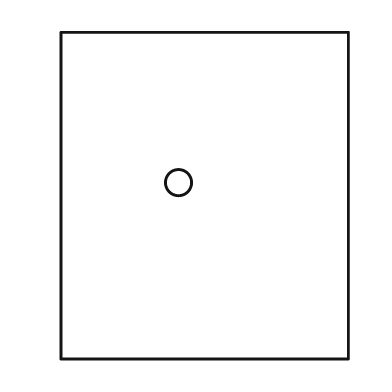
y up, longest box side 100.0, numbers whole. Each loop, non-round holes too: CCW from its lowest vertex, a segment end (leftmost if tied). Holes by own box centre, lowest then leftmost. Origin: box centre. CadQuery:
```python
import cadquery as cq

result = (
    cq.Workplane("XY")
    .moveTo(-44.0, -50.0)
    .lineTo(44.0, -50.0)
    .lineTo(44.0, 50.0)
    .lineTo(-44.0, 50.0)
    .close()
    .moveTo(-8.0, 4.0)
    .circle(4.0)
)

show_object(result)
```